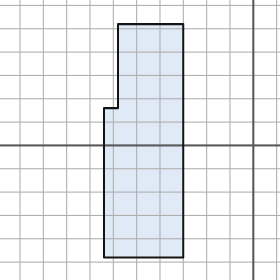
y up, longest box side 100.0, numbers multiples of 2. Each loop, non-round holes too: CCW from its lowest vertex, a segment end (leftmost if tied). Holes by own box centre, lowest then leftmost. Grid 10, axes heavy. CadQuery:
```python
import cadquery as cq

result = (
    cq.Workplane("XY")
    .moveTo(-64.0, -48.0)
    .lineTo(-30.0, -48.0)
    .lineTo(-30.0, 52.0)
    .lineTo(-58.0, 52.0)
    .lineTo(-58.0, 16.0)
    .lineTo(-64.0, 16.0)
    .close()
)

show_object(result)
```